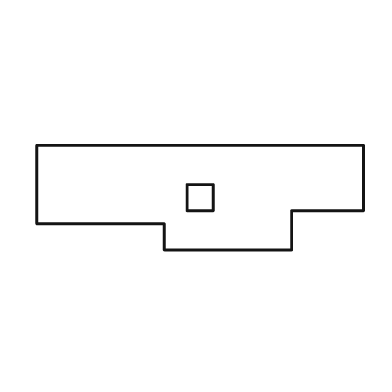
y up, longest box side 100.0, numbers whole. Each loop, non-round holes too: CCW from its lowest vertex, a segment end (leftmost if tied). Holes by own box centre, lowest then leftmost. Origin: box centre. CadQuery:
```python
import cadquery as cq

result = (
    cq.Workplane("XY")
    .moveTo(-11.0, -16.0)
    .lineTo(28.0, -16.0)
    .lineTo(28.0, -4.0)
    .lineTo(50.0, -4.0)
    .lineTo(50.0, 16.0)
    .lineTo(-50.0, 16.0)
    .lineTo(-50.0, -8.0)
    .lineTo(-11.0, -8.0)
    .close()
    .moveTo(-4.0, -4.0)
    .lineTo(4.0, -4.0)
    .lineTo(4.0, 4.0)
    .lineTo(-4.0, 4.0)
    .close()
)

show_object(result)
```